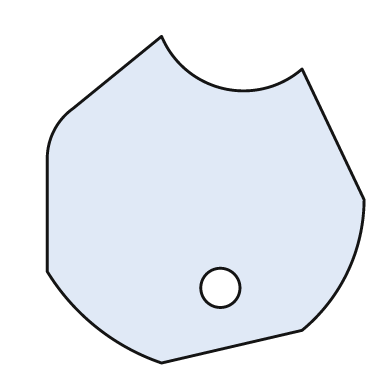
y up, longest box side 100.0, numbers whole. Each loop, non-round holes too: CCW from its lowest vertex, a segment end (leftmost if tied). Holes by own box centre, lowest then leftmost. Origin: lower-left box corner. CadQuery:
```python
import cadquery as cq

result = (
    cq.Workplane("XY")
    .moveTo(35.0, 0.0)
    .lineTo(78.0, 10.0)
    .threePointArc((92.0, 28.0), (97.0, 50.0))
    .lineTo(78.0, 90.0)
    .threePointArc((54.0, 84.0), (35.0, 100.0))
    .lineTo(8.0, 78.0)
    .threePointArc((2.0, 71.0), (0.0, 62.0))
    .lineTo(0.0, 28.0)
    .threePointArc((15.0, 11.0), (35.0, 0.0))
    .close()
    .moveTo(53.0, 23.0)
    .circle(6.0)
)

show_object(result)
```